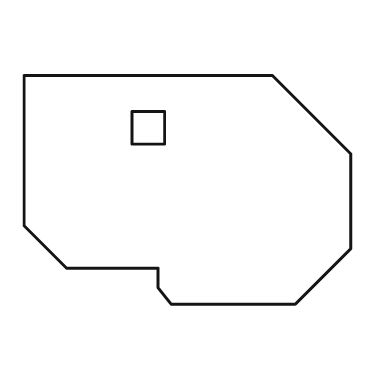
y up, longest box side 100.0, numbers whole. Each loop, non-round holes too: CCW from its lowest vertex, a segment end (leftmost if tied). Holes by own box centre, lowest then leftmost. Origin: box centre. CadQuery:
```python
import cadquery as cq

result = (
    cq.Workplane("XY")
    .moveTo(-5.0, -35.0)
    .lineTo(33.0, -35.0)
    .lineTo(50.0, -18.0)
    .lineTo(50.0, 11.0)
    .lineTo(26.0, 35.0)
    .lineTo(-50.0, 35.0)
    .lineTo(-50.0, -11.0)
    .lineTo(-37.0, -24.0)
    .lineTo(-9.0, -24.0)
    .lineTo(-9.0, -30.0)
    .close()
    .moveTo(-17.0, 14.0)
    .lineTo(-7.0, 14.0)
    .lineTo(-7.0, 24.0)
    .lineTo(-17.0, 24.0)
    .close()
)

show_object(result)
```